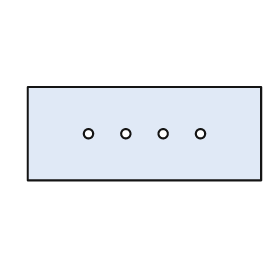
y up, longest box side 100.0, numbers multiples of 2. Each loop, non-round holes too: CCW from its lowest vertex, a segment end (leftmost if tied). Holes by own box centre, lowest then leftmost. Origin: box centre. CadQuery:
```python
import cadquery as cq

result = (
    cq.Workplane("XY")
    .moveTo(-50.0, -20.0)
    .lineTo(50.0, -20.0)
    .lineTo(50.0, 20.0)
    .lineTo(-50.0, 20.0)
    .close()
    .moveTo(-24.0, 0.0)
    .circle(2.0)
    .moveTo(-8.0, 0.0)
    .circle(2.0)
    .moveTo(8.0, 0.0)
    .circle(2.0)
    .moveTo(24.0, 0.0)
    .circle(2.0)
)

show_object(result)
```